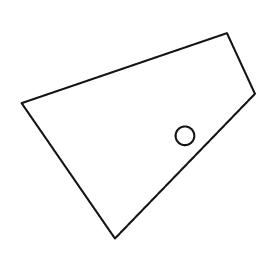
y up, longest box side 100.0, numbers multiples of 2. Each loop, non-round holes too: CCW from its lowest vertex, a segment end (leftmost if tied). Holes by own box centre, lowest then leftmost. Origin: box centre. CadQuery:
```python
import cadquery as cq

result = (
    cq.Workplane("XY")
    .moveTo(-10.0, -44.0)
    .lineTo(50.0, 18.0)
    .lineTo(38.0, 44.0)
    .lineTo(-50.0, 14.0)
    .close()
    .moveTo(20.0, 0.0)
    .circle(4.0)
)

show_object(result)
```